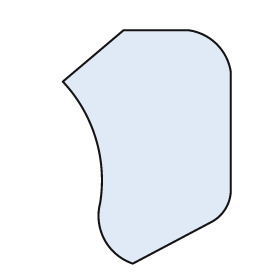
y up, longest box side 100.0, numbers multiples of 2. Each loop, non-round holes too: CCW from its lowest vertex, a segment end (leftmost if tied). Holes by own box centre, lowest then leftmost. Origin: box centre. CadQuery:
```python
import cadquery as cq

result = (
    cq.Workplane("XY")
    .moveTo(-6.0, -50.0)
    .lineTo(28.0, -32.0)
    .threePointArc((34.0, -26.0), (36.0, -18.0))
    .lineTo(36.0, 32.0)
    .threePointArc((30.0, 44.0), (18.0, 50.0))
    .lineTo(-10.0, 50.0)
    .lineTo(-36.0, 28.0)
    .threePointArc((-22.0, 4.0), (-20.0, -24.0))
    .threePointArc((-18.0, -40.0), (-6.0, -50.0))
    .close()
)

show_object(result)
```